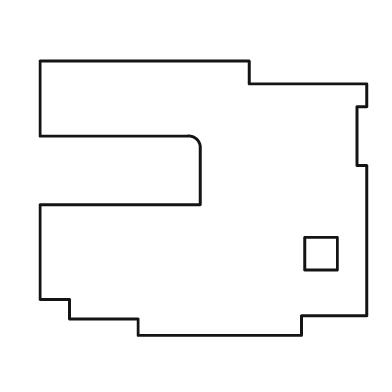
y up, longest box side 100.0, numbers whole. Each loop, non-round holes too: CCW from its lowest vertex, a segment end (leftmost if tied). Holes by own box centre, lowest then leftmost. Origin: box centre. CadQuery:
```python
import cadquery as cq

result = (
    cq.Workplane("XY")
    .moveTo(-20.0, -42.0)
    .lineTo(30.0, -42.0)
    .lineTo(30.0, -36.0)
    .lineTo(50.0, -36.0)
    .lineTo(50.0, 10.0)
    .lineTo(47.0, 10.0)
    .lineTo(47.0, 28.0)
    .lineTo(50.0, 28.0)
    .lineTo(50.0, 35.0)
    .lineTo(14.0, 35.0)
    .lineTo(14.0, 42.0)
    .lineTo(-50.0, 42.0)
    .lineTo(-50.0, 19.0)
    .lineTo(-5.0, 19.0)
    .threePointArc((-2.0, 18.0), (-1.0, 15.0))
    .lineTo(-1.0, -2.0)
    .lineTo(-50.0, -2.0)
    .lineTo(-50.0, -31.0)
    .lineTo(-41.0, -31.0)
    .lineTo(-41.0, -37.0)
    .lineTo(-20.0, -37.0)
    .close()
    .moveTo(31.0, -22.0)
    .lineTo(41.0, -22.0)
    .lineTo(41.0, -12.0)
    .lineTo(31.0, -12.0)
    .close()
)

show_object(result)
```